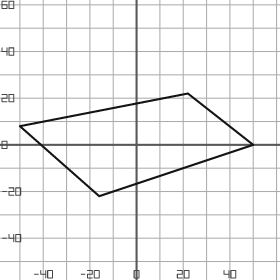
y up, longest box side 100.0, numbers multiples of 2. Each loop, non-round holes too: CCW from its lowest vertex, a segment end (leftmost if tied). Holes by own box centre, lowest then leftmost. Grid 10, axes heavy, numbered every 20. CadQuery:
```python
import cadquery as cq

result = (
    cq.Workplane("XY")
    .moveTo(-16.0, -22.0)
    .lineTo(50.0, 0.0)
    .lineTo(22.0, 22.0)
    .lineTo(-50.0, 8.0)
    .close()
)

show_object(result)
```